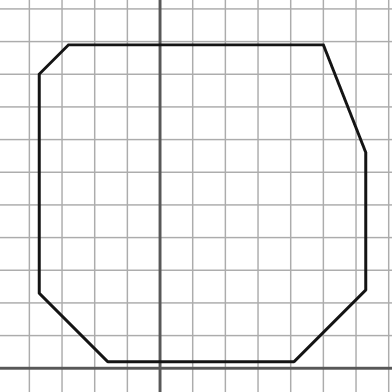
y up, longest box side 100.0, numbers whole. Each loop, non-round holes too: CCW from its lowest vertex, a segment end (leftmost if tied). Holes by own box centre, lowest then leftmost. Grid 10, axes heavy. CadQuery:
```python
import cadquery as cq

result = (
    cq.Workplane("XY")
    .moveTo(-16.0, 2.0)
    .lineTo(41.0, 2.0)
    .lineTo(63.0, 24.0)
    .lineTo(63.0, 66.0)
    .lineTo(50.0, 99.0)
    .lineTo(-28.0, 99.0)
    .lineTo(-37.0, 90.0)
    .lineTo(-37.0, 23.0)
    .close()
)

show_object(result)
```